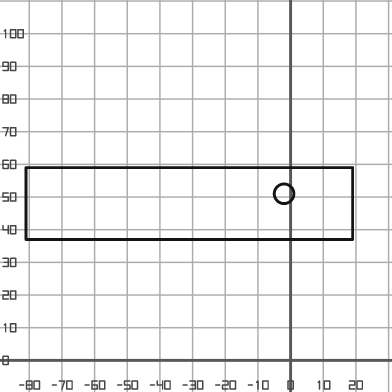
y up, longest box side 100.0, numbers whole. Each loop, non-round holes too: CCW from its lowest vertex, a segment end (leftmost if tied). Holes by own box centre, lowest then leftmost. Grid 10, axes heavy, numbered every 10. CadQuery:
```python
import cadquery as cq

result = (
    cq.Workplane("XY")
    .moveTo(-81.0, 37.0)
    .lineTo(19.0, 37.0)
    .lineTo(19.0, 59.0)
    .lineTo(-81.0, 59.0)
    .close()
    .moveTo(-2.0, 51.0)
    .circle(3.0)
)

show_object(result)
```